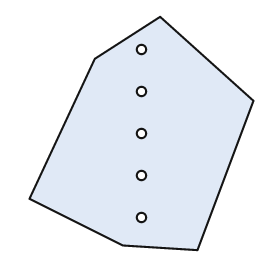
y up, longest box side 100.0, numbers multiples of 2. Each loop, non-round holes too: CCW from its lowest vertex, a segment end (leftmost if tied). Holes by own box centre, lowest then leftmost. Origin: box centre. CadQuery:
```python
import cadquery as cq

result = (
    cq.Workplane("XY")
    .moveTo(24.0, -50.0)
    .lineTo(48.0, 14.0)
    .lineTo(8.0, 50.0)
    .lineTo(-20.0, 32.0)
    .lineTo(-48.0, -28.0)
    .lineTo(-8.0, -48.0)
    .close()
    .moveTo(0.0, -36.0)
    .circle(2.0)
    .moveTo(0.0, -18.0)
    .circle(2.0)
    .moveTo(0.0, 0.0)
    .circle(2.0)
    .moveTo(0.0, 18.0)
    .circle(2.0)
    .moveTo(0.0, 36.0)
    .circle(2.0)
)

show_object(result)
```